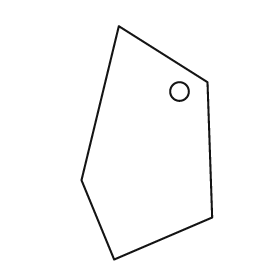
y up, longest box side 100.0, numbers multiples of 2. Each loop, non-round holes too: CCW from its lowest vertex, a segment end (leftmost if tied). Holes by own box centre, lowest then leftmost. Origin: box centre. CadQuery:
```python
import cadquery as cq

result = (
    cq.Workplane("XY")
    .moveTo(-14.0, -50.0)
    .lineTo(28.0, -32.0)
    .lineTo(26.0, 26.0)
    .lineTo(-12.0, 50.0)
    .lineTo(-28.0, -16.0)
    .close()
    .moveTo(14.0, 22.0)
    .circle(4.0)
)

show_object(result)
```